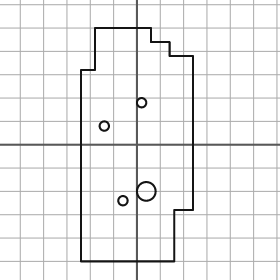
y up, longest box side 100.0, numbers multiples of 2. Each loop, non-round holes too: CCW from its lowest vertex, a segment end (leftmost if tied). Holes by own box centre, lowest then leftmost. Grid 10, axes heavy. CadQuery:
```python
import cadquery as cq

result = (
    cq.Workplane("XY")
    .moveTo(-24.0, -50.0)
    .lineTo(16.0, -50.0)
    .lineTo(16.0, -28.0)
    .lineTo(24.0, -28.0)
    .lineTo(24.0, 38.0)
    .lineTo(14.0, 38.0)
    .lineTo(14.0, 44.0)
    .lineTo(6.0, 44.0)
    .lineTo(6.0, 50.0)
    .lineTo(-18.0, 50.0)
    .lineTo(-18.0, 32.0)
    .lineTo(-24.0, 32.0)
    .close()
    .moveTo(-6.0, -24.0)
    .circle(2.0)
    .moveTo(4.0, -20.0)
    .circle(4.0)
    .moveTo(-14.0, 8.0)
    .circle(2.0)
    .moveTo(2.0, 18.0)
    .circle(2.0)
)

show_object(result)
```